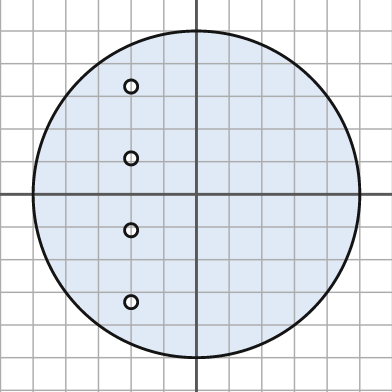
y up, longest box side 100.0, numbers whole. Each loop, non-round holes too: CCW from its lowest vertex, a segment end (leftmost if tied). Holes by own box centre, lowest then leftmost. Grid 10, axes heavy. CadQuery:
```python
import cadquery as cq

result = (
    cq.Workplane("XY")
    .moveTo(0.0, 0.0)
    .circle(50.0)
    .moveTo(-20.0, -33.0)
    .circle(2.0)
    .moveTo(-20.0, -11.0)
    .circle(2.0)
    .moveTo(-20.0, 11.0)
    .circle(2.0)
    .moveTo(-20.0, 33.0)
    .circle(2.0)
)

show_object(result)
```